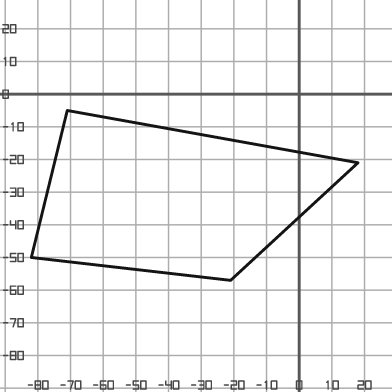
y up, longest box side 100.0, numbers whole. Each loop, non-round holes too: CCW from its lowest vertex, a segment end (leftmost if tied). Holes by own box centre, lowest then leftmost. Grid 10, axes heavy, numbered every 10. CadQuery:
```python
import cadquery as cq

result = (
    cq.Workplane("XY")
    .moveTo(-21.0, -57.0)
    .lineTo(18.0, -21.0)
    .lineTo(-71.0, -5.0)
    .lineTo(-82.0, -50.0)
    .close()
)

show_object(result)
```